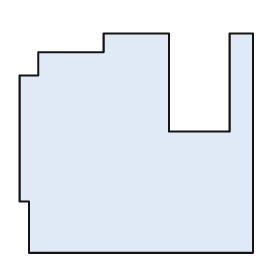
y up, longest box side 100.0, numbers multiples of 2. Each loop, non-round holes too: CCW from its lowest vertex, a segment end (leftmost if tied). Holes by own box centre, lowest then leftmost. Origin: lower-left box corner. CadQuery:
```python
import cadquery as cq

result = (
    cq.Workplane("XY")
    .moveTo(4.0, 0.0)
    .lineTo(100.0, 0.0)
    .lineTo(100.0, 94.0)
    .lineTo(90.0, 94.0)
    .lineTo(90.0, 52.0)
    .lineTo(64.0, 52.0)
    .lineTo(64.0, 94.0)
    .lineTo(36.0, 94.0)
    .lineTo(36.0, 86.0)
    .lineTo(8.0, 86.0)
    .lineTo(8.0, 76.0)
    .lineTo(0.0, 76.0)
    .lineTo(0.0, 22.0)
    .lineTo(4.0, 22.0)
    .close()
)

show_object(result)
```